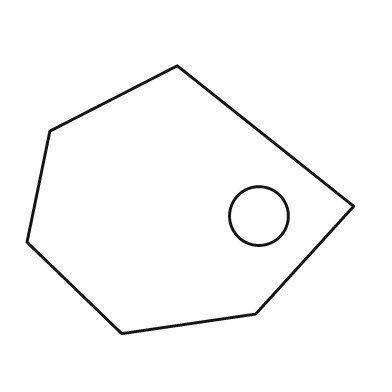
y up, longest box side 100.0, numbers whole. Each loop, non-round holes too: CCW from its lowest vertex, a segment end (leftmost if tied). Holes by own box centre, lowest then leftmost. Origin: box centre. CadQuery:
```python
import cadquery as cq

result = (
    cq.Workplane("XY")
    .moveTo(-21.0, -41.0)
    .lineTo(20.0, -35.0)
    .lineTo(50.0, -2.0)
    .lineTo(-4.0, 41.0)
    .lineTo(-43.0, 21.0)
    .lineTo(-50.0, -13.0)
    .close()
    .moveTo(21.0, -5.0)
    .circle(9.0)
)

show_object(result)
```